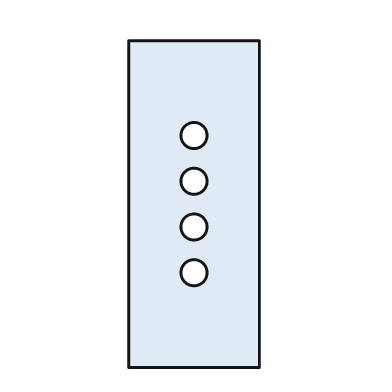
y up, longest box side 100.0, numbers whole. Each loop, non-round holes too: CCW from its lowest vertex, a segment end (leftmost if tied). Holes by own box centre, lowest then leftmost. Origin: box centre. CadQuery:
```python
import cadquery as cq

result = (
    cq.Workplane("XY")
    .moveTo(-20.0, -50.0)
    .lineTo(20.0, -50.0)
    .lineTo(20.0, 50.0)
    .lineTo(-20.0, 50.0)
    .close()
    .moveTo(0.0, -21.0)
    .circle(4.0)
    .moveTo(0.0, -7.0)
    .circle(4.0)
    .moveTo(0.0, 7.0)
    .circle(4.0)
    .moveTo(0.0, 21.0)
    .circle(4.0)
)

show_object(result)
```